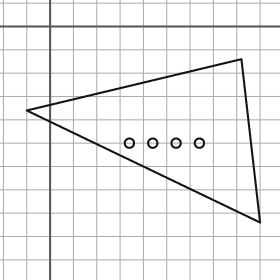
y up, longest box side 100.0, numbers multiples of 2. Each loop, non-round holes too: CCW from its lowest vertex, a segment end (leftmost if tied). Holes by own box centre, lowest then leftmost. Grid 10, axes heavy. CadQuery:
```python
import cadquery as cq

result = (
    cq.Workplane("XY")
    .moveTo(90.0, -84.0)
    .lineTo(82.0, -14.0)
    .lineTo(-10.0, -36.0)
    .close()
    .moveTo(34.0, -50.0)
    .circle(2.0)
    .moveTo(44.0, -50.0)
    .circle(2.0)
    .moveTo(54.0, -50.0)
    .circle(2.0)
    .moveTo(64.0, -50.0)
    .circle(2.0)
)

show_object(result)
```